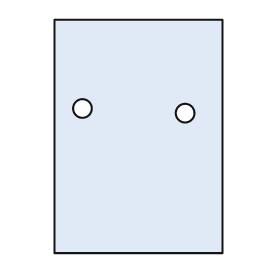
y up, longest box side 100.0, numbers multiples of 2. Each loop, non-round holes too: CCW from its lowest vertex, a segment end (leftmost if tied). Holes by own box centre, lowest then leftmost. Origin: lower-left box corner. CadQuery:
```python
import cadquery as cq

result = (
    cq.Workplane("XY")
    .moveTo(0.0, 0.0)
    .lineTo(72.0, 0.0)
    .lineTo(72.0, 100.0)
    .lineTo(0.0, 100.0)
    .close()
    .moveTo(56.0, 60.0)
    .circle(4.0)
    .moveTo(12.0, 62.0)
    .circle(4.0)
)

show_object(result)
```